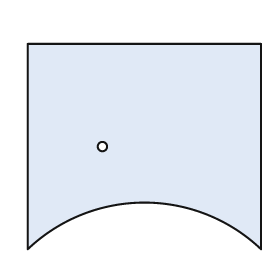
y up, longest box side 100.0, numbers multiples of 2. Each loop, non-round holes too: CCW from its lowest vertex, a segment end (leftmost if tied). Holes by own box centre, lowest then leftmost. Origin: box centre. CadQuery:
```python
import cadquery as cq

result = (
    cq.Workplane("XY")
    .moveTo(-50.0, -44.0)
    .threePointArc((0.0, -24.0), (50.0, -44.0))
    .lineTo(50.0, 44.0)
    .lineTo(-50.0, 44.0)
    .close()
    .moveTo(-18.0, 0.0)
    .circle(2.0)
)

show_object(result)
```